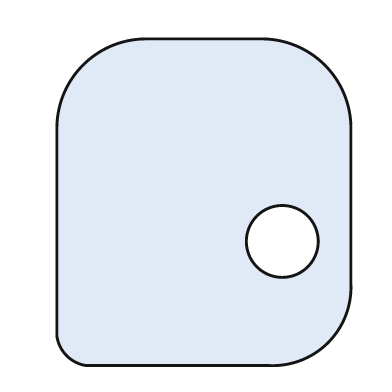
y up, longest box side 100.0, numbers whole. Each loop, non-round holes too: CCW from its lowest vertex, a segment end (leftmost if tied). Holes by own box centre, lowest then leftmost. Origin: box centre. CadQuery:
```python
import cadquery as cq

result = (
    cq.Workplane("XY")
    .moveTo(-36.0, -50.0)
    .lineTo(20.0, -50.0)
    .threePointArc((38.0, -43.0), (45.0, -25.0))
    .lineTo(45.0, 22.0)
    .threePointArc((37.0, 42.0), (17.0, 50.0))
    .lineTo(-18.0, 50.0)
    .threePointArc((-37.0, 42.0), (-45.0, 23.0))
    .lineTo(-45.0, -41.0)
    .threePointArc((-42.0, -47.0), (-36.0, -50.0))
    .close()
    .moveTo(24.0, -12.0)
    .circle(11.0)
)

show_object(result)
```